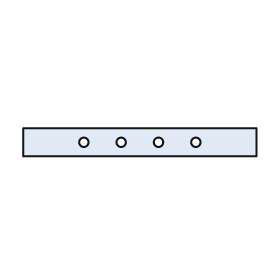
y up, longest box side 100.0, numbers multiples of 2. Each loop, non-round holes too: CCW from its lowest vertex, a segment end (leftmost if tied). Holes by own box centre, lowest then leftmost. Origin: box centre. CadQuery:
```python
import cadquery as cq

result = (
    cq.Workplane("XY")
    .moveTo(-50.0, -6.0)
    .lineTo(50.0, -6.0)
    .lineTo(50.0, 6.0)
    .lineTo(-50.0, 6.0)
    .close()
    .moveTo(-24.0, 0.0)
    .circle(2.0)
    .moveTo(-8.0, 0.0)
    .circle(2.0)
    .moveTo(8.0, 0.0)
    .circle(2.0)
    .moveTo(24.0, 0.0)
    .circle(2.0)
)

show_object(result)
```